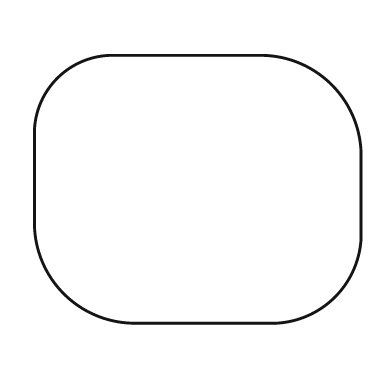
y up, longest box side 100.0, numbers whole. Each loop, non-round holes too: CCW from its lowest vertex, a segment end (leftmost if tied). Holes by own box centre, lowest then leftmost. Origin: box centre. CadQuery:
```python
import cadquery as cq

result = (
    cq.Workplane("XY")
    .moveTo(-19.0, -41.0)
    .lineTo(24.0, -41.0)
    .threePointArc((42.0, -33.0), (50.0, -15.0))
    .lineTo(50.0, 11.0)
    .threePointArc((41.0, 32.0), (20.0, 41.0))
    .lineTo(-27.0, 41.0)
    .threePointArc((-43.0, 34.0), (-50.0, 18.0))
    .lineTo(-50.0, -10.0)
    .threePointArc((-41.0, -32.0), (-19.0, -41.0))
    .close()
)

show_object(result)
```